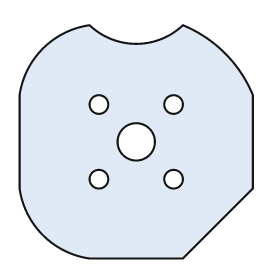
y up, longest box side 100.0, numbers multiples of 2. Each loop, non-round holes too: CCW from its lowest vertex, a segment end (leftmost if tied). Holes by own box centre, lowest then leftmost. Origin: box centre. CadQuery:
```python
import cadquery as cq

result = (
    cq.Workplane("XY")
    .moveTo(-20.0, -50.0)
    .lineTo(20.0, -50.0)
    .lineTo(50.0, -20.0)
    .lineTo(50.0, 20.0)
    .threePointArc((38.0, 38.0), (20.0, 50.0))
    .threePointArc((0.0, 42.0), (-20.0, 50.0))
    .threePointArc((-40.0, 40.0), (-50.0, 20.0))
    .lineTo(-50.0, -20.0)
    .threePointArc((-40.0, -40.0), (-20.0, -50.0))
    .close()
    .moveTo(-16.0, -16.0)
    .circle(4.0)
    .moveTo(16.0, -16.0)
    .circle(4.0)
    .moveTo(0.0, 0.0)
    .circle(8.0)
    .moveTo(-16.0, 16.0)
    .circle(4.0)
    .moveTo(16.0, 16.0)
    .circle(4.0)
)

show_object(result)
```